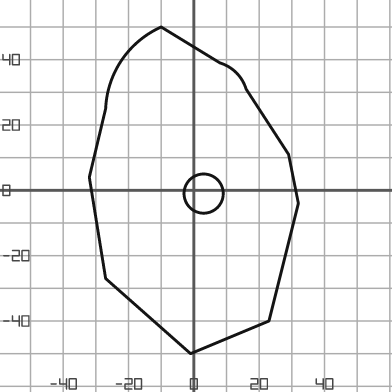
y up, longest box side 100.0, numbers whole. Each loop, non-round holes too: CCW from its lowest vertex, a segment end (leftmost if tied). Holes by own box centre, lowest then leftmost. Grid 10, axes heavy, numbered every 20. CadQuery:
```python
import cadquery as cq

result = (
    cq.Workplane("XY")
    .moveTo(-1.0, -50.0)
    .lineTo(23.0, -40.0)
    .lineTo(32.0, -4.0)
    .lineTo(29.0, 11.0)
    .lineTo(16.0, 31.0)
    .threePointArc((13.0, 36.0), (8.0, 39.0))
    .lineTo(-10.0, 50.0)
    .threePointArc((-22.0, 40.0), (-27.0, 25.0))
    .lineTo(-32.0, 4.0)
    .lineTo(-27.0, -27.0)
    .close()
    .moveTo(3.0, -1.0)
    .circle(6.0)
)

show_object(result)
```